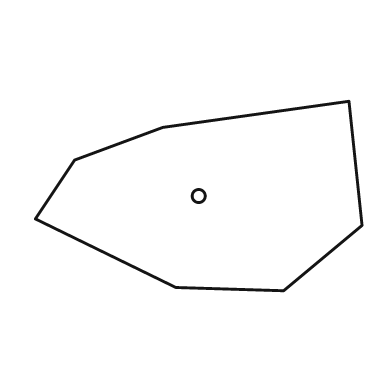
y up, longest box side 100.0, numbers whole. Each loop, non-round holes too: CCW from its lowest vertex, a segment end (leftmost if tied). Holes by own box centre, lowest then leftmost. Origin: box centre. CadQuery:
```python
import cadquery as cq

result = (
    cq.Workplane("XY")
    .moveTo(26.0, -29.0)
    .lineTo(50.0, -9.0)
    .lineTo(46.0, 29.0)
    .lineTo(-11.0, 21.0)
    .lineTo(-38.0, 11.0)
    .lineTo(-50.0, -7.0)
    .lineTo(-7.0, -28.0)
    .close()
    .moveTo(0.0, 0.0)
    .circle(2.0)
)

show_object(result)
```